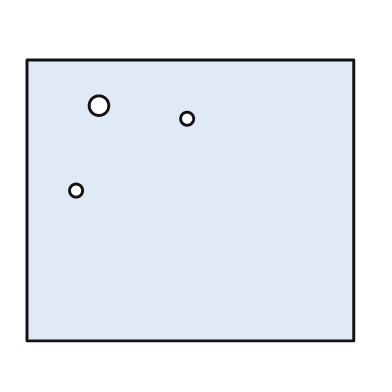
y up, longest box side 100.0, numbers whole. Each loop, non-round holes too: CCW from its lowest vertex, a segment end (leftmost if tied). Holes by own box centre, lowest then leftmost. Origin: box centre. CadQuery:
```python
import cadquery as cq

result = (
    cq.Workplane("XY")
    .moveTo(-50.0, -43.0)
    .lineTo(50.0, -43.0)
    .lineTo(50.0, 43.0)
    .lineTo(-50.0, 43.0)
    .close()
    .moveTo(-35.0, 3.0)
    .circle(2.0)
    .moveTo(-1.0, 25.0)
    .circle(2.0)
    .moveTo(-28.0, 29.0)
    .circle(3.0)
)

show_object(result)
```